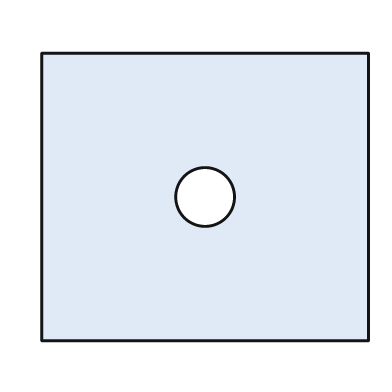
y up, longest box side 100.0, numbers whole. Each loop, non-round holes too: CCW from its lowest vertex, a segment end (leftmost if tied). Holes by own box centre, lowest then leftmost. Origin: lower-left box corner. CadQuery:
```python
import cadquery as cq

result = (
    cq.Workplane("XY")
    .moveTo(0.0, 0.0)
    .lineTo(100.0, 0.0)
    .lineTo(100.0, 88.0)
    .lineTo(0.0, 88.0)
    .close()
    .moveTo(50.0, 44.0)
    .circle(9.0)
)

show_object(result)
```